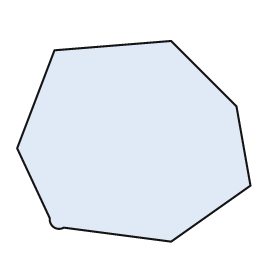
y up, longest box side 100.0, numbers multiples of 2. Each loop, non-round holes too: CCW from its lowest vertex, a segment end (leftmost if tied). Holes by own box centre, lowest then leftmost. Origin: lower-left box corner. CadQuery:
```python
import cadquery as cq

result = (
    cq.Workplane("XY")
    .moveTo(66.0, 0.0)
    .lineTo(100.0, 24.0)
    .lineTo(94.0, 58.0)
    .lineTo(66.0, 86.0)
    .lineTo(16.0, 82.0)
    .lineTo(0.0, 40.0)
    .lineTo(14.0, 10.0)
    .threePointArc((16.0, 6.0), (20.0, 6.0))
    .close()
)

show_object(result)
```